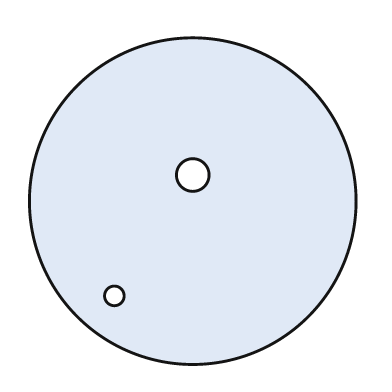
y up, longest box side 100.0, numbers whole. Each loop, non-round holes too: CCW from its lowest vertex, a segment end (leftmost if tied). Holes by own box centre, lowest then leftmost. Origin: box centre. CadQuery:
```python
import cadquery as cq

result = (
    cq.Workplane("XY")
    .moveTo(0.0, 0.0)
    .circle(50.0)
    .moveTo(-24.0, -29.0)
    .circle(3.0)
    .moveTo(0.0, 8.0)
    .circle(5.0)
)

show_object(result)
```